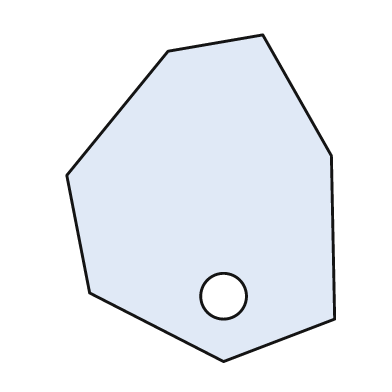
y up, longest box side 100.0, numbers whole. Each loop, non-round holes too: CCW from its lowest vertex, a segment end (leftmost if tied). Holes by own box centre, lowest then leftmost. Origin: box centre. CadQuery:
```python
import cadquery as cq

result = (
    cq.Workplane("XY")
    .moveTo(7.0, -50.0)
    .lineTo(41.0, -37.0)
    .lineTo(40.0, 13.0)
    .lineTo(19.0, 50.0)
    .lineTo(-10.0, 45.0)
    .lineTo(-41.0, 7.0)
    .lineTo(-34.0, -29.0)
    .close()
    .moveTo(7.0, -30.0)
    .circle(7.0)
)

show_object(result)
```